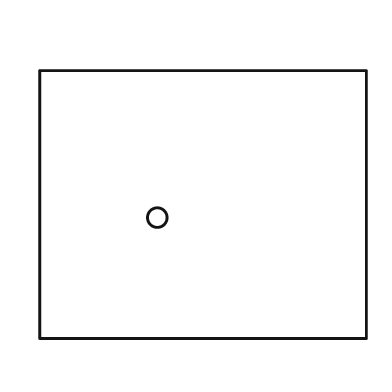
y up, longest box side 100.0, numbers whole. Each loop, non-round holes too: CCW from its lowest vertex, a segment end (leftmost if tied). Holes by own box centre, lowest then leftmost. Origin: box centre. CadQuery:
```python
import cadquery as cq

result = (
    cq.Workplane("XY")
    .moveTo(-50.0, -41.0)
    .lineTo(50.0, -41.0)
    .lineTo(50.0, 41.0)
    .lineTo(-50.0, 41.0)
    .close()
    .moveTo(-14.0, -4.0)
    .circle(3.0)
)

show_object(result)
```